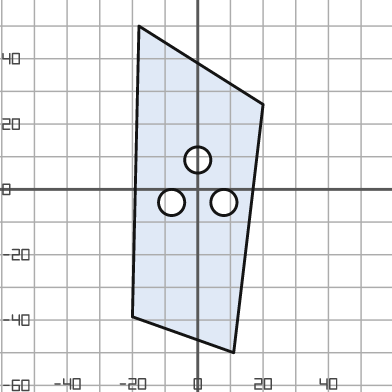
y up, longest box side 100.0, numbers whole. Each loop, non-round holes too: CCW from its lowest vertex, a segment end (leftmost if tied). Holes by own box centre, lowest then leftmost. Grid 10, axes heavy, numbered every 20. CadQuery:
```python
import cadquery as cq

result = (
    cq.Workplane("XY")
    .moveTo(11.0, -50.0)
    .lineTo(20.0, 26.0)
    .lineTo(-18.0, 50.0)
    .lineTo(-20.0, -39.0)
    .close()
    .moveTo(-8.0, -4.0)
    .circle(4.0)
    .moveTo(8.0, -4.0)
    .circle(4.0)
    .moveTo(0.0, 9.0)
    .circle(4.0)
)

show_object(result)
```